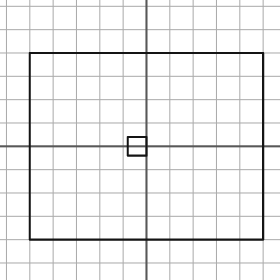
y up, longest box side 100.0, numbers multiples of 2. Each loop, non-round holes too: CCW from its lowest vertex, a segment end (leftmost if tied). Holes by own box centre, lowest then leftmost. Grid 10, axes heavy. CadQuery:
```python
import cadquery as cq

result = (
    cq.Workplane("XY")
    .moveTo(-50.0, -40.0)
    .lineTo(50.0, -40.0)
    .lineTo(50.0, 40.0)
    .lineTo(-50.0, 40.0)
    .close()
    .moveTo(-8.0, -4.0)
    .lineTo(0.0, -4.0)
    .lineTo(0.0, 4.0)
    .lineTo(-8.0, 4.0)
    .close()
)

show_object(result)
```